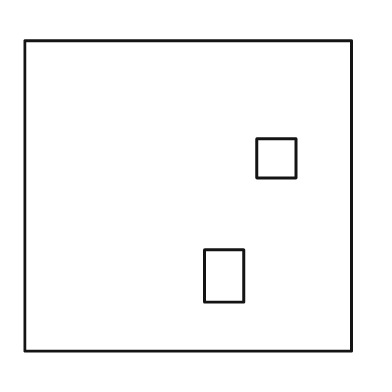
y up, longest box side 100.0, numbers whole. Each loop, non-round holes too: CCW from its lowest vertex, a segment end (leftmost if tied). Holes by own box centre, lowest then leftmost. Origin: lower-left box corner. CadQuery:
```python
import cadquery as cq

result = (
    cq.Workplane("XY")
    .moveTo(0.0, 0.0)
    .lineTo(100.0, 0.0)
    .lineTo(100.0, 95.0)
    .lineTo(0.0, 95.0)
    .close()
    .moveTo(55.0, 15.0)
    .lineTo(67.0, 15.0)
    .lineTo(67.0, 31.0)
    .lineTo(55.0, 31.0)
    .close()
    .moveTo(71.0, 53.0)
    .lineTo(83.0, 53.0)
    .lineTo(83.0, 65.0)
    .lineTo(71.0, 65.0)
    .close()
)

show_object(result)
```